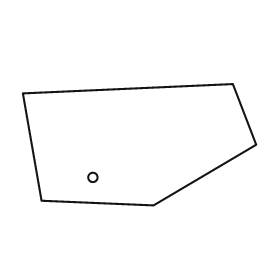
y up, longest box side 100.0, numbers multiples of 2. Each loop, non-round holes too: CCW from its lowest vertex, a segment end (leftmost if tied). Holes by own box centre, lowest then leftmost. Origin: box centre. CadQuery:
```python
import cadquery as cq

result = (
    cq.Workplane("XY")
    .moveTo(6.0, -26.0)
    .lineTo(50.0, 0.0)
    .lineTo(40.0, 26.0)
    .lineTo(-50.0, 22.0)
    .lineTo(-42.0, -24.0)
    .close()
    .moveTo(-20.0, -14.0)
    .circle(2.0)
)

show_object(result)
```